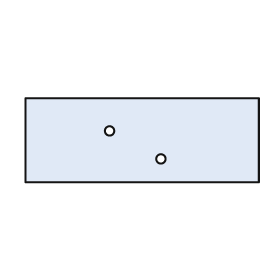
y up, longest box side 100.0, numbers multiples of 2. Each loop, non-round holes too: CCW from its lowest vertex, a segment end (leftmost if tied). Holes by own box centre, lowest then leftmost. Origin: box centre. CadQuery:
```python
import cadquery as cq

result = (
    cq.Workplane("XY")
    .moveTo(-50.0, -18.0)
    .lineTo(50.0, -18.0)
    .lineTo(50.0, 18.0)
    .lineTo(-50.0, 18.0)
    .close()
    .moveTo(8.0, -8.0)
    .circle(2.0)
    .moveTo(-14.0, 4.0)
    .circle(2.0)
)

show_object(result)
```